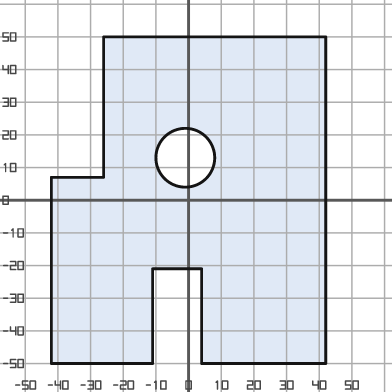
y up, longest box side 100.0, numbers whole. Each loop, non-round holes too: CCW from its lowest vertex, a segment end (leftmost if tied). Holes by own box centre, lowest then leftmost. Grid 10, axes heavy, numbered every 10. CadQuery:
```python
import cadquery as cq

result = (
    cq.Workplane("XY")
    .moveTo(-42.0, -50.0)
    .lineTo(-11.0, -50.0)
    .lineTo(-11.0, -21.0)
    .lineTo(4.0, -21.0)
    .lineTo(4.0, -50.0)
    .lineTo(42.0, -50.0)
    .lineTo(42.0, 50.0)
    .lineTo(-26.0, 50.0)
    .lineTo(-26.0, 7.0)
    .lineTo(-42.0, 7.0)
    .close()
    .moveTo(-1.0, 13.0)
    .circle(9.0)
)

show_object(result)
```